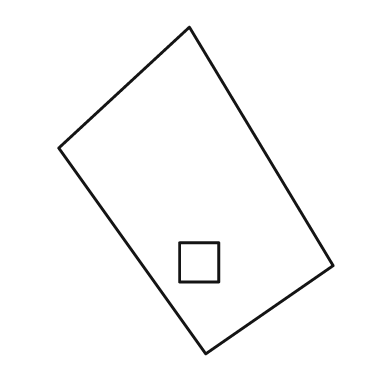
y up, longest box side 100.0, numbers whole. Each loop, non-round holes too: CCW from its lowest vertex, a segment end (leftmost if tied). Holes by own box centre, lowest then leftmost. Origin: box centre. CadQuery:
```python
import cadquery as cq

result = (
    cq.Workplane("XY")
    .moveTo(3.0, -50.0)
    .lineTo(42.0, -23.0)
    .lineTo(-2.0, 50.0)
    .lineTo(-42.0, 13.0)
    .close()
    .moveTo(-5.0, -28.0)
    .lineTo(7.0, -28.0)
    .lineTo(7.0, -16.0)
    .lineTo(-5.0, -16.0)
    .close()
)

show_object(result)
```